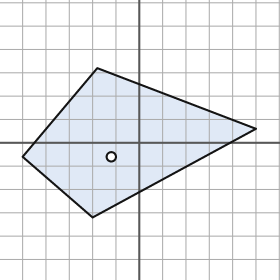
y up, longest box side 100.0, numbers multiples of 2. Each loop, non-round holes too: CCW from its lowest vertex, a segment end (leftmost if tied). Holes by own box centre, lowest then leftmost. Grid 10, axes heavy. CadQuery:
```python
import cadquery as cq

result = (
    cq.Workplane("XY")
    .moveTo(-20.0, -32.0)
    .lineTo(50.0, 6.0)
    .lineTo(-18.0, 32.0)
    .lineTo(-50.0, -6.0)
    .close()
    .moveTo(-12.0, -6.0)
    .circle(2.0)
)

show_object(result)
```